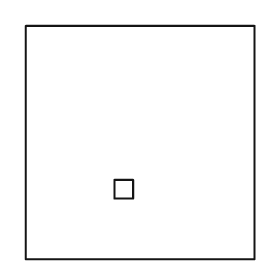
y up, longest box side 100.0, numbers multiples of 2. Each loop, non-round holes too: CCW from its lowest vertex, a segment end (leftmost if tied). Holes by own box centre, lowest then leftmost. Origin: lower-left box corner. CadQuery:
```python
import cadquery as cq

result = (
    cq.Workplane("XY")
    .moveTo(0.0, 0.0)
    .lineTo(98.0, 0.0)
    .lineTo(98.0, 100.0)
    .lineTo(0.0, 100.0)
    .close()
    .moveTo(38.0, 26.0)
    .lineTo(46.0, 26.0)
    .lineTo(46.0, 34.0)
    .lineTo(38.0, 34.0)
    .close()
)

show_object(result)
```